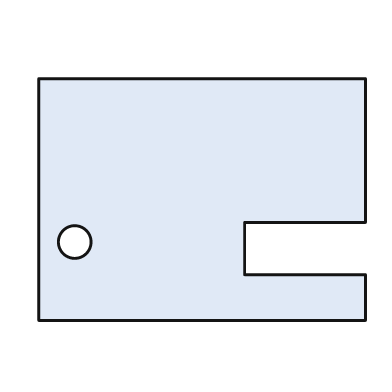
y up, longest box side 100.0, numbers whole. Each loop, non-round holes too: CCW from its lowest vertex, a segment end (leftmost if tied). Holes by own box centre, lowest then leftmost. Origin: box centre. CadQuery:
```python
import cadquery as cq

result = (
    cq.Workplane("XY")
    .moveTo(-50.0, -37.0)
    .lineTo(50.0, -37.0)
    .lineTo(50.0, -23.0)
    .lineTo(13.0, -23.0)
    .lineTo(13.0, -7.0)
    .lineTo(50.0, -7.0)
    .lineTo(50.0, 37.0)
    .lineTo(-50.0, 37.0)
    .close()
    .moveTo(-39.0, -13.0)
    .circle(5.0)
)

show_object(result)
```